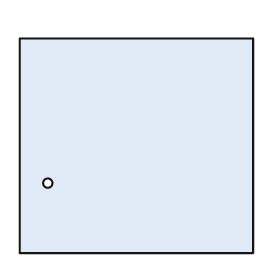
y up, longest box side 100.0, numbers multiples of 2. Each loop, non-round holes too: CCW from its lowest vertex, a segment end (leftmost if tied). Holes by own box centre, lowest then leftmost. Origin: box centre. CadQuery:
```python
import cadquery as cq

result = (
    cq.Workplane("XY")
    .moveTo(-50.0, -46.0)
    .lineTo(50.0, -46.0)
    .lineTo(50.0, 46.0)
    .lineTo(-50.0, 46.0)
    .close()
    .moveTo(-38.0, -16.0)
    .circle(2.0)
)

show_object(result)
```